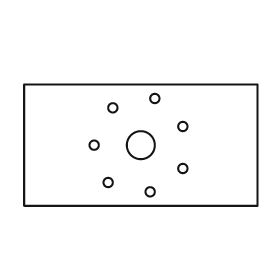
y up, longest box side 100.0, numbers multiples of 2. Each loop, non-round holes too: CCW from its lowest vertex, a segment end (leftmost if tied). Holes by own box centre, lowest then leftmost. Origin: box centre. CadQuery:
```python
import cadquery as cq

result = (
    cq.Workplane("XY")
    .moveTo(-50.0, -26.0)
    .lineTo(50.0, -26.0)
    .lineTo(50.0, 26.0)
    .lineTo(-50.0, 26.0)
    .close()
    .moveTo(4.0, -20.0)
    .circle(2.0)
    .moveTo(-14.0, -16.0)
    .circle(2.0)
    .moveTo(18.0, -10.0)
    .circle(2.0)
    .moveTo(-20.0, 0.0)
    .circle(2.0)
    .moveTo(0.0, 0.0)
    .circle(6.0)
    .moveTo(18.0, 8.0)
    .circle(2.0)
    .moveTo(-12.0, 16.0)
    .circle(2.0)
    .moveTo(6.0, 20.0)
    .circle(2.0)
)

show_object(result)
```